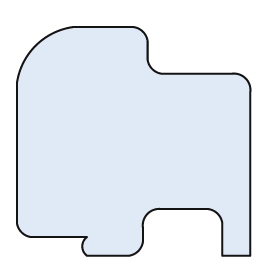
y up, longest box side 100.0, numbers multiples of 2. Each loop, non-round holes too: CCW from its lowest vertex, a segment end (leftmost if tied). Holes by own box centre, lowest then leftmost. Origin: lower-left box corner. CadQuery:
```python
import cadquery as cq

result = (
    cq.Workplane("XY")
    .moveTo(30.0, 0.0)
    .lineTo(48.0, 0.0)
    .threePointArc((52.0, 2.0), (54.0, 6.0))
    .lineTo(54.0, 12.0)
    .threePointArc((56.0, 18.0), (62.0, 20.0))
    .lineTo(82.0, 20.0)
    .threePointArc((86.0, 18.0), (88.0, 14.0))
    .lineTo(88.0, 0.0)
    .lineTo(100.0, 0.0)
    .lineTo(100.0, 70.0)
    .threePointArc((98.0, 76.0), (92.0, 78.0))
    .lineTo(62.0, 78.0)
    .threePointArc((58.0, 80.0), (56.0, 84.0))
    .lineTo(56.0, 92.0)
    .threePointArc((54.0, 96.0), (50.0, 98.0))
    .lineTo(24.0, 98.0)
    .threePointArc((8.0, 90.0), (0.0, 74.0))
    .lineTo(0.0, 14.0)
    .threePointArc((2.0, 10.0), (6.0, 8.0))
    .lineTo(30.0, 8.0)
    .threePointArc((28.0, 4.0), (30.0, 0.0))
    .close()
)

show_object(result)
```